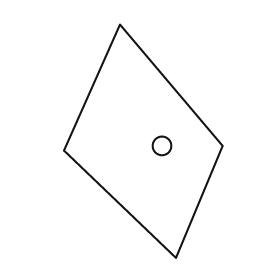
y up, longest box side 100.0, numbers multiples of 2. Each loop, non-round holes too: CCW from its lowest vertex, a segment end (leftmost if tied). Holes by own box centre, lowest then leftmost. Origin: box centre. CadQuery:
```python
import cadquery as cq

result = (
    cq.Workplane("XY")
    .moveTo(14.0, -50.0)
    .lineTo(34.0, -2.0)
    .lineTo(-10.0, 50.0)
    .lineTo(-34.0, -4.0)
    .close()
    .moveTo(8.0, -2.0)
    .circle(4.0)
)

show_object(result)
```